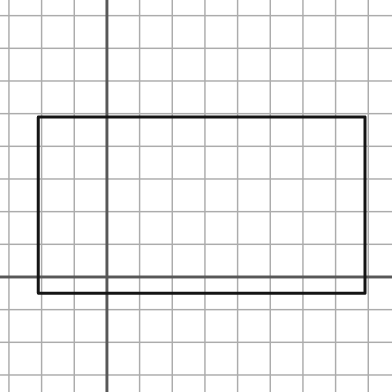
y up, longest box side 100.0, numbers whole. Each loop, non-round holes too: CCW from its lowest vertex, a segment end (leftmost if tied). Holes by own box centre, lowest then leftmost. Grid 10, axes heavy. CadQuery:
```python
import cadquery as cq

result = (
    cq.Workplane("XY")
    .moveTo(-21.0, -5.0)
    .lineTo(79.0, -5.0)
    .lineTo(79.0, 49.0)
    .lineTo(-21.0, 49.0)
    .close()
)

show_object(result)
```